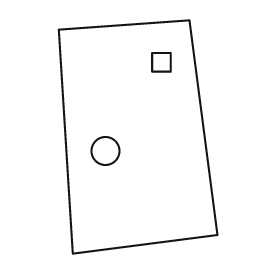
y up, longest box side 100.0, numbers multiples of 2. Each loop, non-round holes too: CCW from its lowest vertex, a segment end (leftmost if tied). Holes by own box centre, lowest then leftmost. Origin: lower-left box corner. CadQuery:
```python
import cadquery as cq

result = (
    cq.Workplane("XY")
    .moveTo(6.0, 0.0)
    .lineTo(68.0, 8.0)
    .lineTo(56.0, 100.0)
    .lineTo(0.0, 96.0)
    .close()
    .moveTo(20.0, 44.0)
    .circle(6.0)
    .moveTo(40.0, 78.0)
    .lineTo(48.0, 78.0)
    .lineTo(48.0, 86.0)
    .lineTo(40.0, 86.0)
    .close()
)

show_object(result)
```